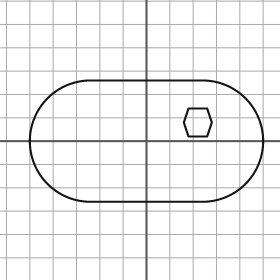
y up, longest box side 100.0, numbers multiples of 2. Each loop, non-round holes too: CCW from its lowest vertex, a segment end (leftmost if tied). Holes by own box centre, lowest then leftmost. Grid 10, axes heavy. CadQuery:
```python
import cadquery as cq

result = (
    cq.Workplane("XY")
    .moveTo(-24.0, -26.0)
    .lineTo(24.0, -26.0)
    .threePointArc((50.0, 0.0), (24.0, 26.0))
    .lineTo(-24.0, 26.0)
    .threePointArc((-50.0, 0.0), (-24.0, -26.0))
    .close()
    .moveTo(18.0, 2.0)
    .lineTo(26.0, 2.0)
    .lineTo(28.0, 8.0)
    .lineTo(26.0, 14.0)
    .lineTo(18.0, 14.0)
    .lineTo(16.0, 8.0)
    .close()
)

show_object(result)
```